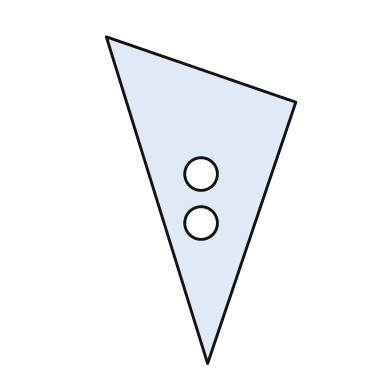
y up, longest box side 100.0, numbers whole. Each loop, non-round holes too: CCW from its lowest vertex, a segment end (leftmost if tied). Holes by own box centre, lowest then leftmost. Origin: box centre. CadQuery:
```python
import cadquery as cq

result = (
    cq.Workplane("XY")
    .moveTo(2.0, -50.0)
    .lineTo(29.0, 30.0)
    .lineTo(-29.0, 50.0)
    .close()
    .moveTo(0.0, -7.0)
    .circle(5.0)
    .moveTo(0.0, 8.0)
    .circle(5.0)
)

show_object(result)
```